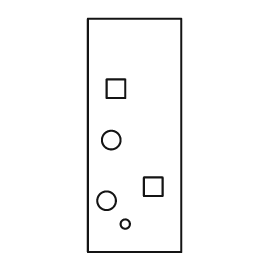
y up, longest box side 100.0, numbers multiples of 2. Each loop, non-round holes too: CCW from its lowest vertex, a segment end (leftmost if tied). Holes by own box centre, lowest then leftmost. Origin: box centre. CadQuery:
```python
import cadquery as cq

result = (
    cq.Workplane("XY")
    .moveTo(-20.0, -50.0)
    .lineTo(20.0, -50.0)
    .lineTo(20.0, 50.0)
    .lineTo(-20.0, 50.0)
    .close()
    .moveTo(-4.0, -38.0)
    .circle(2.0)
    .moveTo(-12.0, -28.0)
    .circle(4.0)
    .moveTo(4.0, -26.0)
    .lineTo(12.0, -26.0)
    .lineTo(12.0, -18.0)
    .lineTo(4.0, -18.0)
    .close()
    .moveTo(-10.0, -2.0)
    .circle(4.0)
    .moveTo(-12.0, 16.0)
    .lineTo(-4.0, 16.0)
    .lineTo(-4.0, 24.0)
    .lineTo(-12.0, 24.0)
    .close()
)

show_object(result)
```